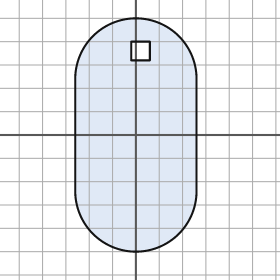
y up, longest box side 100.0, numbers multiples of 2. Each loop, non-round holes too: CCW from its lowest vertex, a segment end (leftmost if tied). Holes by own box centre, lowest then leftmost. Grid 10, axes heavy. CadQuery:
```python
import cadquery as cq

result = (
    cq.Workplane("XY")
    .moveTo(-26.0, -24.0)
    .threePointArc((0.0, -50.0), (26.0, -24.0))
    .lineTo(26.0, 24.0)
    .threePointArc((0.0, 50.0), (-26.0, 24.0))
    .close()
    .moveTo(-2.0, 32.0)
    .lineTo(6.0, 32.0)
    .lineTo(6.0, 40.0)
    .lineTo(-2.0, 40.0)
    .close()
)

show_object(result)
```